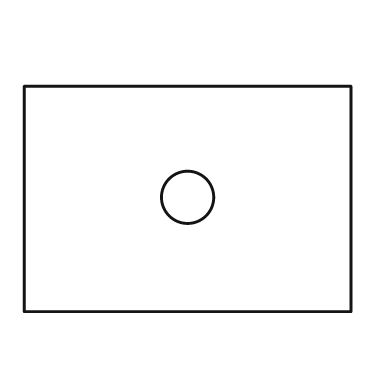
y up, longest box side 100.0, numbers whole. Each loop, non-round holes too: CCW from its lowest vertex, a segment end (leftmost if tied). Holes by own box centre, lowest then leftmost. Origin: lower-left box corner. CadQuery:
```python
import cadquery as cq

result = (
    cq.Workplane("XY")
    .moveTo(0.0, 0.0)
    .lineTo(100.0, 0.0)
    .lineTo(100.0, 69.0)
    .lineTo(0.0, 69.0)
    .close()
    .moveTo(50.0, 35.0)
    .circle(8.0)
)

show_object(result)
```